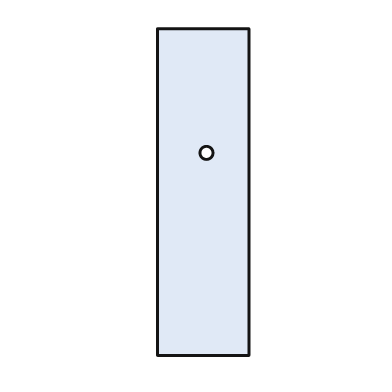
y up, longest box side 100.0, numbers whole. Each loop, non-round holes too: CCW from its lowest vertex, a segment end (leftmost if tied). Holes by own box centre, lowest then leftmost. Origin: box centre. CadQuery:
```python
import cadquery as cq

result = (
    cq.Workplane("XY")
    .moveTo(-14.0, -50.0)
    .lineTo(14.0, -50.0)
    .lineTo(14.0, 50.0)
    .lineTo(-14.0, 50.0)
    .close()
    .moveTo(1.0, 12.0)
    .circle(2.0)
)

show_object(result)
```